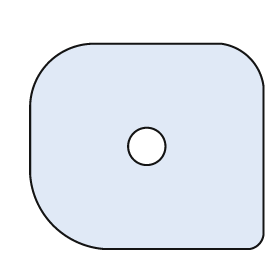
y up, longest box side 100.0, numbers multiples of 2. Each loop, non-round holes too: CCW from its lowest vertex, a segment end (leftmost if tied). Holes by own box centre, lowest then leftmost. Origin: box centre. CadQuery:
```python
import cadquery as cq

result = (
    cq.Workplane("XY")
    .moveTo(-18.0, -44.0)
    .lineTo(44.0, -44.0)
    .threePointArc((48.0, -42.0), (50.0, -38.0))
    .lineTo(50.0, 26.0)
    .threePointArc((44.0, 38.0), (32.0, 44.0))
    .lineTo(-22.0, 44.0)
    .threePointArc((-42.0, 36.0), (-50.0, 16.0))
    .lineTo(-50.0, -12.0)
    .threePointArc((-40.0, -34.0), (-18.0, -44.0))
    .close()
    .moveTo(0.0, 0.0)
    .circle(8.0)
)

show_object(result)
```